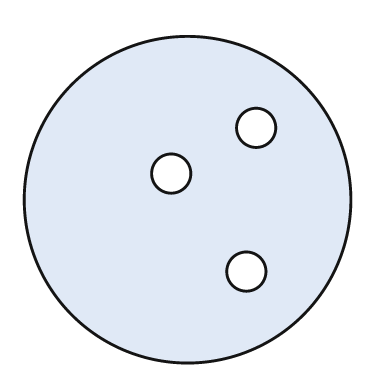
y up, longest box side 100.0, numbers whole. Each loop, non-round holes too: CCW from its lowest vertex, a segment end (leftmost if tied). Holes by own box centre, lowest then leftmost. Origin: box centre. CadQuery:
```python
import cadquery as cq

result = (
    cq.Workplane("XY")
    .moveTo(0.0, 0.0)
    .circle(50.0)
    .moveTo(18.0, -22.0)
    .circle(6.0)
    .moveTo(-5.0, 8.0)
    .circle(6.0)
    .moveTo(21.0, 22.0)
    .circle(6.0)
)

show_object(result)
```